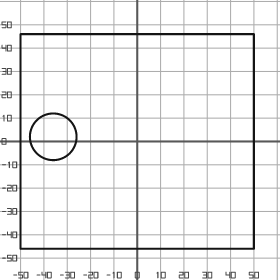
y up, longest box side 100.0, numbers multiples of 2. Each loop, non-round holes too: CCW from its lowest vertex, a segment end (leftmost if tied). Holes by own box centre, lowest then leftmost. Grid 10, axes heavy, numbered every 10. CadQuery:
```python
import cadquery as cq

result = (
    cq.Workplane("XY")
    .moveTo(-50.0, -46.0)
    .lineTo(50.0, -46.0)
    .lineTo(50.0, 46.0)
    .lineTo(-50.0, 46.0)
    .close()
    .moveTo(-36.0, 2.0)
    .circle(10.0)
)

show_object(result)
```